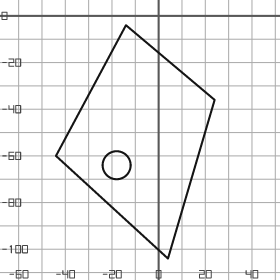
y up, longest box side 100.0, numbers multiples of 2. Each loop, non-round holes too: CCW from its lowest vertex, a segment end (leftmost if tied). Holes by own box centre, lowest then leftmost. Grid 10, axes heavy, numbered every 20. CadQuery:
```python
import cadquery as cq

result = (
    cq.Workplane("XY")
    .moveTo(4.0, -104.0)
    .lineTo(24.0, -36.0)
    .lineTo(-14.0, -4.0)
    .lineTo(-44.0, -60.0)
    .close()
    .moveTo(-18.0, -64.0)
    .circle(6.0)
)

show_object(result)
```